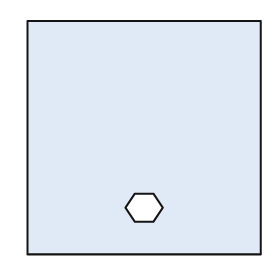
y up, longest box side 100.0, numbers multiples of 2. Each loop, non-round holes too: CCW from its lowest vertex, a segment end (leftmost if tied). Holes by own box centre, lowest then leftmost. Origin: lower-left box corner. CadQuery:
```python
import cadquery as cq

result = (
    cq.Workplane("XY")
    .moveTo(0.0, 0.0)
    .lineTo(100.0, 0.0)
    .lineTo(100.0, 100.0)
    .lineTo(0.0, 100.0)
    .close()
    .moveTo(46.0, 14.0)
    .lineTo(54.0, 14.0)
    .lineTo(58.0, 20.0)
    .lineTo(54.0, 26.0)
    .lineTo(46.0, 26.0)
    .lineTo(42.0, 20.0)
    .close()
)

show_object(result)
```